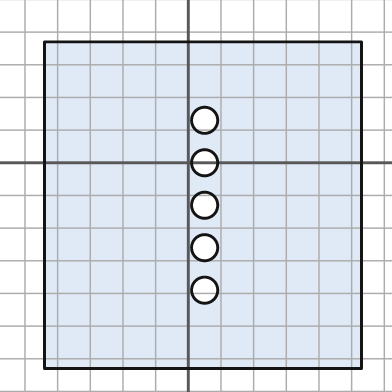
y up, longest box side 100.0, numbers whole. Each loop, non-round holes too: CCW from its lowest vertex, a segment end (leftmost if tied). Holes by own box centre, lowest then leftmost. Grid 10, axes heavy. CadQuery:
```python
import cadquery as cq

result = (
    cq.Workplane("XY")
    .moveTo(-44.0, -63.0)
    .lineTo(53.0, -63.0)
    .lineTo(53.0, 37.0)
    .lineTo(-44.0, 37.0)
    .close()
    .moveTo(5.0, -39.0)
    .circle(4.0)
    .moveTo(5.0, -26.0)
    .circle(4.0)
    .moveTo(5.0, -13.0)
    .circle(4.0)
    .moveTo(5.0, 0.0)
    .circle(4.0)
    .moveTo(5.0, 13.0)
    .circle(4.0)
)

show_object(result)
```